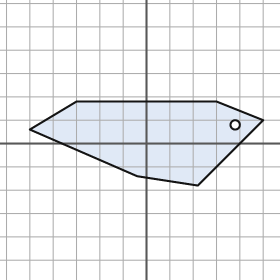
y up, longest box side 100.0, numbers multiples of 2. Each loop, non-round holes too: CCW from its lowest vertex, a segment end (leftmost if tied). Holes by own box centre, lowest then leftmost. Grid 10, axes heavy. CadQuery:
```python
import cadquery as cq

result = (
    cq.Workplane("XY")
    .moveTo(22.0, -18.0)
    .lineTo(50.0, 10.0)
    .lineTo(30.0, 18.0)
    .lineTo(-30.0, 18.0)
    .lineTo(-50.0, 6.0)
    .lineTo(-4.0, -14.0)
    .close()
    .moveTo(38.0, 8.0)
    .circle(2.0)
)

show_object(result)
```